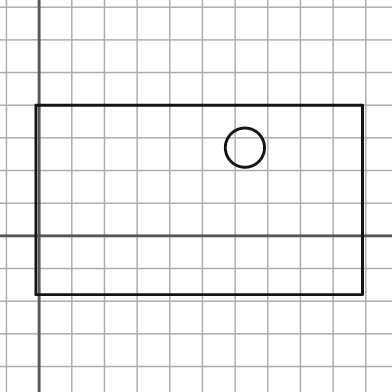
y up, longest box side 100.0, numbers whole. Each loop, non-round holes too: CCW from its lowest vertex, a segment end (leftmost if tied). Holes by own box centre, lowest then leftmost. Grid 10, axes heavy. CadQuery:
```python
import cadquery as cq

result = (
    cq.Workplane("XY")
    .moveTo(-1.0, -18.0)
    .lineTo(99.0, -18.0)
    .lineTo(99.0, 40.0)
    .lineTo(-1.0, 40.0)
    .close()
    .moveTo(63.0, 27.0)
    .circle(6.0)
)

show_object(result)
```